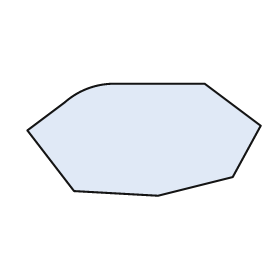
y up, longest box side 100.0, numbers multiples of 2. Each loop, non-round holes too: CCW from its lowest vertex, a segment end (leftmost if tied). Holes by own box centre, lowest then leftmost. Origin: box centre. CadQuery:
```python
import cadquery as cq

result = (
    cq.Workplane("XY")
    .moveTo(6.0, -24.0)
    .lineTo(38.0, -16.0)
    .lineTo(50.0, 6.0)
    .lineTo(26.0, 24.0)
    .lineTo(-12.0, 24.0)
    .threePointArc((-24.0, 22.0), (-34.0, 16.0))
    .lineTo(-50.0, 4.0)
    .lineTo(-30.0, -22.0)
    .close()
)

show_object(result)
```